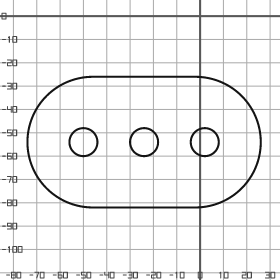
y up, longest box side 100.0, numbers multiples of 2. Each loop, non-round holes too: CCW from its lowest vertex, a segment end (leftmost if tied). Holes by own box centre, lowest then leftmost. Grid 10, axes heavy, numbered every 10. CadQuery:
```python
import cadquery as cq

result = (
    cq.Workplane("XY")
    .moveTo(-46.0, -82.0)
    .lineTo(-2.0, -82.0)
    .threePointArc((26.0, -54.0), (-2.0, -26.0))
    .lineTo(-46.0, -26.0)
    .threePointArc((-74.0, -54.0), (-46.0, -82.0))
    .close()
    .moveTo(-50.0, -54.0)
    .circle(6.0)
    .moveTo(-24.0, -54.0)
    .circle(6.0)
    .moveTo(2.0, -54.0)
    .circle(6.0)
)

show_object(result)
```